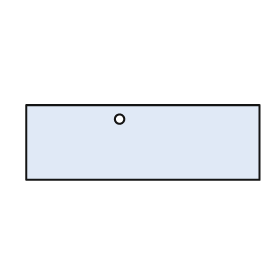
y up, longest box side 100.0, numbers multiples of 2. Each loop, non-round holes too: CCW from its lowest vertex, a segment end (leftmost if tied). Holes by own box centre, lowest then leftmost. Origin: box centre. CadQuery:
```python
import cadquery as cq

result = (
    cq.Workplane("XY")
    .moveTo(-50.0, -16.0)
    .lineTo(50.0, -16.0)
    .lineTo(50.0, 16.0)
    .lineTo(-50.0, 16.0)
    .close()
    .moveTo(-10.0, 10.0)
    .circle(2.0)
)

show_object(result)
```